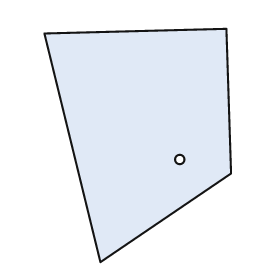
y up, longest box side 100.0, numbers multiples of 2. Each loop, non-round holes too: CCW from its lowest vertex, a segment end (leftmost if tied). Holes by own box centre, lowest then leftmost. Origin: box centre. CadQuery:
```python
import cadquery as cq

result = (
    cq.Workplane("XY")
    .moveTo(-16.0, -50.0)
    .lineTo(40.0, -12.0)
    .lineTo(38.0, 50.0)
    .lineTo(-40.0, 48.0)
    .close()
    .moveTo(18.0, -6.0)
    .circle(2.0)
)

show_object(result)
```